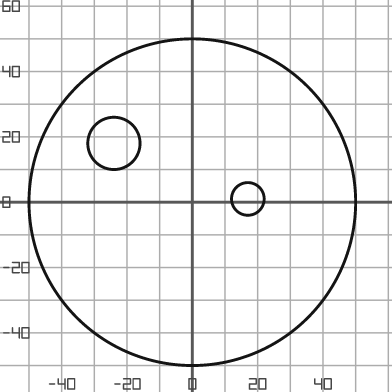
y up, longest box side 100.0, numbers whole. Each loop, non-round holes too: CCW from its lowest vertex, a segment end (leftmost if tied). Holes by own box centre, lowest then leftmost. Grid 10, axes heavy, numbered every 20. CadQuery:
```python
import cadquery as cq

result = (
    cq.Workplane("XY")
    .moveTo(0.0, 0.0)
    .circle(50.0)
    .moveTo(17.0, 1.0)
    .circle(5.0)
    .moveTo(-24.0, 18.0)
    .circle(8.0)
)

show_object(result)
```